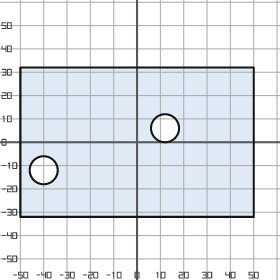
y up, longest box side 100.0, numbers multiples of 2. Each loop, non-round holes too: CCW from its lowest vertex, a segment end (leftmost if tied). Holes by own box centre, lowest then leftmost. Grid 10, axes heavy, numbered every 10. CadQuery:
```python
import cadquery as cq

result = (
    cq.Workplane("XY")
    .moveTo(-50.0, -32.0)
    .lineTo(50.0, -32.0)
    .lineTo(50.0, 32.0)
    .lineTo(-50.0, 32.0)
    .close()
    .moveTo(-40.0, -12.0)
    .circle(6.0)
    .moveTo(12.0, 6.0)
    .circle(6.0)
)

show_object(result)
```